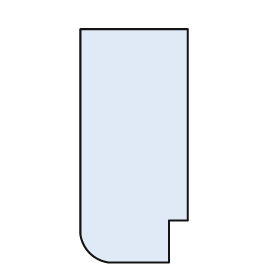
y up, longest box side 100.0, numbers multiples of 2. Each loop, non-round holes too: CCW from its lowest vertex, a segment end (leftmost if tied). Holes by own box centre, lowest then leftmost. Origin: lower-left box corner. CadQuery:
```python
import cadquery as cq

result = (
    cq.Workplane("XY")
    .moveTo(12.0, 0.0)
    .lineTo(38.0, 0.0)
    .lineTo(38.0, 18.0)
    .lineTo(46.0, 18.0)
    .lineTo(46.0, 100.0)
    .lineTo(0.0, 100.0)
    .lineTo(0.0, 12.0)
    .threePointArc((4.0, 4.0), (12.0, 0.0))
    .close()
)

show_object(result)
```